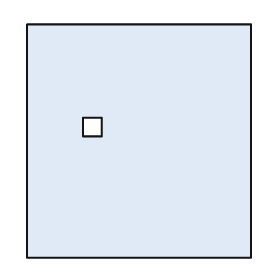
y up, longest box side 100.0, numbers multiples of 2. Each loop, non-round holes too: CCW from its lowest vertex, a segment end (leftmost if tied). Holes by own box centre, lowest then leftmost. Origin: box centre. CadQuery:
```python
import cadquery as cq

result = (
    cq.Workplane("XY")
    .moveTo(-48.0, -50.0)
    .lineTo(48.0, -50.0)
    .lineTo(48.0, 50.0)
    .lineTo(-48.0, 50.0)
    .close()
    .moveTo(-24.0, 2.0)
    .lineTo(-16.0, 2.0)
    .lineTo(-16.0, 10.0)
    .lineTo(-24.0, 10.0)
    .close()
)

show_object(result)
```